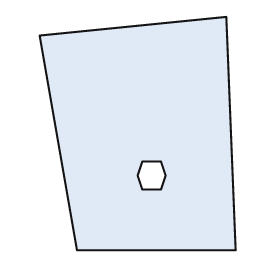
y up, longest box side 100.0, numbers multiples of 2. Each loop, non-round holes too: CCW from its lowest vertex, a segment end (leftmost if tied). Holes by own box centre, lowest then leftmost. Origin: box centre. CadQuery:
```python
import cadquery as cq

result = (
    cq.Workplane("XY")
    .moveTo(-26.0, -50.0)
    .lineTo(42.0, -50.0)
    .lineTo(38.0, 50.0)
    .lineTo(-42.0, 42.0)
    .close()
    .moveTo(2.0, -24.0)
    .lineTo(10.0, -24.0)
    .lineTo(12.0, -18.0)
    .lineTo(10.0, -12.0)
    .lineTo(2.0, -12.0)
    .lineTo(0.0, -18.0)
    .close()
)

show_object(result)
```